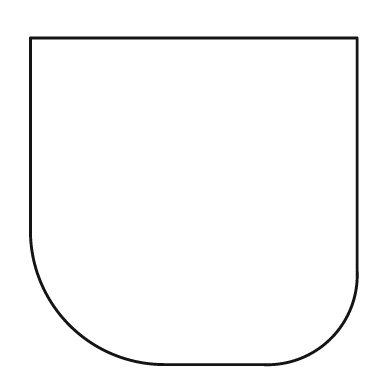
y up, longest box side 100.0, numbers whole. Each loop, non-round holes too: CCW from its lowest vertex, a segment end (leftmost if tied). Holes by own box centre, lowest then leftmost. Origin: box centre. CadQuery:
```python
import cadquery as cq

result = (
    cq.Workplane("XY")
    .moveTo(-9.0, -50.0)
    .lineTo(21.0, -50.0)
    .threePointArc((42.0, -42.0), (50.0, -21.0))
    .lineTo(50.0, 50.0)
    .lineTo(-50.0, 50.0)
    .lineTo(-50.0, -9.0)
    .threePointArc((-38.0, -38.0), (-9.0, -50.0))
    .close()
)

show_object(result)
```